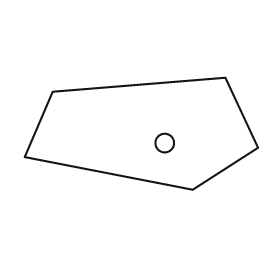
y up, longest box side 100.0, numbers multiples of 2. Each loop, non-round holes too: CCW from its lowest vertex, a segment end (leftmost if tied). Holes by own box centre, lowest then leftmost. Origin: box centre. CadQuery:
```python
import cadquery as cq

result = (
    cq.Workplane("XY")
    .moveTo(22.0, -24.0)
    .lineTo(50.0, -6.0)
    .lineTo(36.0, 24.0)
    .lineTo(-38.0, 18.0)
    .lineTo(-50.0, -10.0)
    .close()
    .moveTo(10.0, -4.0)
    .circle(4.0)
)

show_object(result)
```